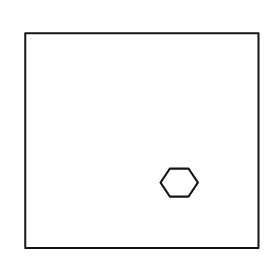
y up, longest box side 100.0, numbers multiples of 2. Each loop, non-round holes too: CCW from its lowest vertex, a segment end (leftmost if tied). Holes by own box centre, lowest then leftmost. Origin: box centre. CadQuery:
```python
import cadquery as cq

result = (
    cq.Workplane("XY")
    .moveTo(-50.0, -46.0)
    .lineTo(50.0, -46.0)
    .lineTo(50.0, 46.0)
    .lineTo(-50.0, 46.0)
    .close()
    .moveTo(12.0, -24.0)
    .lineTo(20.0, -24.0)
    .lineTo(24.0, -18.0)
    .lineTo(20.0, -12.0)
    .lineTo(12.0, -12.0)
    .lineTo(8.0, -18.0)
    .close()
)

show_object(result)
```